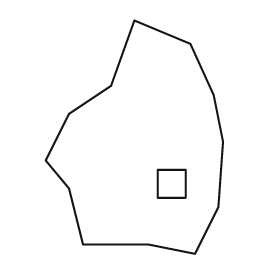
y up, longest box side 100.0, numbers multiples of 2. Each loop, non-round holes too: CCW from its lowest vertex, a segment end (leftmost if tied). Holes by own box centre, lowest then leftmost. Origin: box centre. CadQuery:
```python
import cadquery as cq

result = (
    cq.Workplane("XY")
    .moveTo(26.0, -50.0)
    .lineTo(36.0, -30.0)
    .lineTo(38.0, -2.0)
    .lineTo(34.0, 18.0)
    .lineTo(24.0, 40.0)
    .lineTo(0.0, 50.0)
    .lineTo(-10.0, 22.0)
    .lineTo(-28.0, 10.0)
    .lineTo(-38.0, -10.0)
    .lineTo(-28.0, -22.0)
    .lineTo(-22.0, -46.0)
    .lineTo(6.0, -46.0)
    .close()
    .moveTo(10.0, -26.0)
    .lineTo(22.0, -26.0)
    .lineTo(22.0, -14.0)
    .lineTo(10.0, -14.0)
    .close()
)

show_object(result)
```